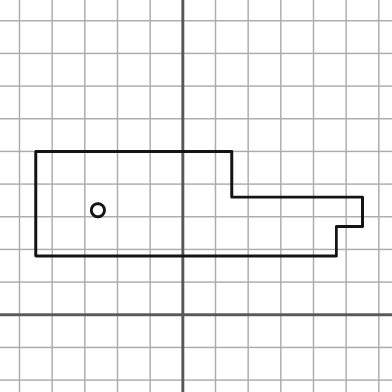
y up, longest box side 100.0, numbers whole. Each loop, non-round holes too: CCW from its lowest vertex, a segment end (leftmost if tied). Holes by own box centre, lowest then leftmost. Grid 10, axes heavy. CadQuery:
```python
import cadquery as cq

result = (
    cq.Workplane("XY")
    .moveTo(-45.0, 18.0)
    .lineTo(47.0, 18.0)
    .lineTo(47.0, 27.0)
    .lineTo(55.0, 27.0)
    .lineTo(55.0, 36.0)
    .lineTo(15.0, 36.0)
    .lineTo(15.0, 50.0)
    .lineTo(-45.0, 50.0)
    .close()
    .moveTo(-26.0, 32.0)
    .circle(2.0)
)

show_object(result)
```